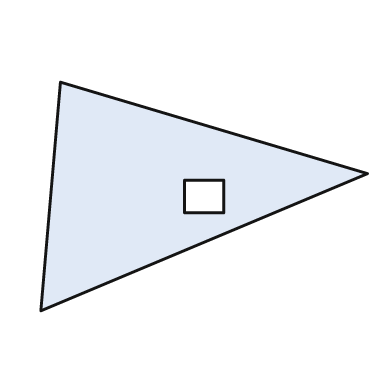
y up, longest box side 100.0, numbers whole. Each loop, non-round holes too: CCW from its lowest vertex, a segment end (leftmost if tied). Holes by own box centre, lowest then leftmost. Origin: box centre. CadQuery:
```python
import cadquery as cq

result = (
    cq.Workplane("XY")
    .moveTo(-50.0, -35.0)
    .lineTo(50.0, 7.0)
    .lineTo(-44.0, 35.0)
    .close()
    .moveTo(-6.0, -5.0)
    .lineTo(6.0, -5.0)
    .lineTo(6.0, 5.0)
    .lineTo(-6.0, 5.0)
    .close()
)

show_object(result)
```